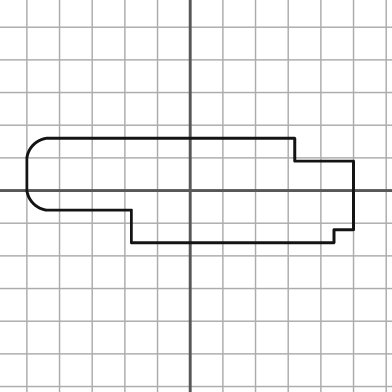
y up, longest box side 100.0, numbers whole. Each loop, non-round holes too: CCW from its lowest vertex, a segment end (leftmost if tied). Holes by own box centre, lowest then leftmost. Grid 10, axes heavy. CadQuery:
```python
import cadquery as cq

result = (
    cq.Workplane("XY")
    .moveTo(-18.0, -16.0)
    .lineTo(44.0, -16.0)
    .lineTo(44.0, -12.0)
    .lineTo(50.0, -12.0)
    .lineTo(50.0, 9.0)
    .lineTo(32.0, 9.0)
    .lineTo(32.0, 16.0)
    .lineTo(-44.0, 16.0)
    .threePointArc((-48.0, 14.0), (-50.0, 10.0))
    .lineTo(-50.0, 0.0)
    .threePointArc((-48.0, -4.0), (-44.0, -6.0))
    .lineTo(-18.0, -6.0)
    .close()
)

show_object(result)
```